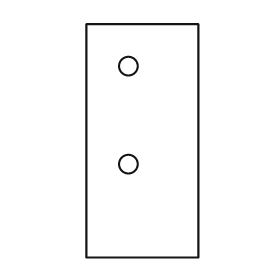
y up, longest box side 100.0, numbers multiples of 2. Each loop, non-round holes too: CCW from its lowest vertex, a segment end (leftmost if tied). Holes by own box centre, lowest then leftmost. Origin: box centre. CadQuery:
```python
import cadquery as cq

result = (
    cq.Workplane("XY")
    .moveTo(-24.0, -50.0)
    .lineTo(24.0, -50.0)
    .lineTo(24.0, 50.0)
    .lineTo(-24.0, 50.0)
    .close()
    .moveTo(-6.0, -10.0)
    .circle(4.0)
    .moveTo(-6.0, 32.0)
    .circle(4.0)
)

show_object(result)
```